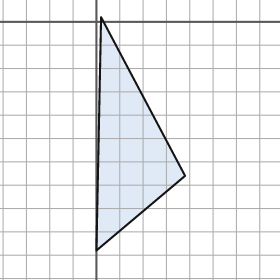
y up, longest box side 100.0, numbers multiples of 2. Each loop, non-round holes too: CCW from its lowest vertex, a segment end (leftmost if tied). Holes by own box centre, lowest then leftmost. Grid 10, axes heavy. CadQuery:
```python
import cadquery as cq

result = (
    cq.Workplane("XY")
    .moveTo(0.0, -98.0)
    .lineTo(38.0, -66.0)
    .lineTo(2.0, 2.0)
    .close()
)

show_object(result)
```